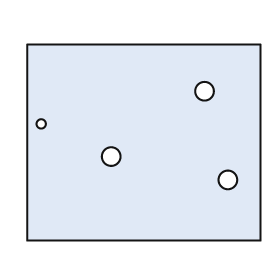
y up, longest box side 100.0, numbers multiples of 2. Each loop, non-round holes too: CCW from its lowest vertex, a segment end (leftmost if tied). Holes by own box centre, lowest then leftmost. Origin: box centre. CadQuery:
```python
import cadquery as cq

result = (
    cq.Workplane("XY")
    .moveTo(-50.0, -42.0)
    .lineTo(50.0, -42.0)
    .lineTo(50.0, 42.0)
    .lineTo(-50.0, 42.0)
    .close()
    .moveTo(36.0, -16.0)
    .circle(4.0)
    .moveTo(-14.0, -6.0)
    .circle(4.0)
    .moveTo(-44.0, 8.0)
    .circle(2.0)
    .moveTo(26.0, 22.0)
    .circle(4.0)
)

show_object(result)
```